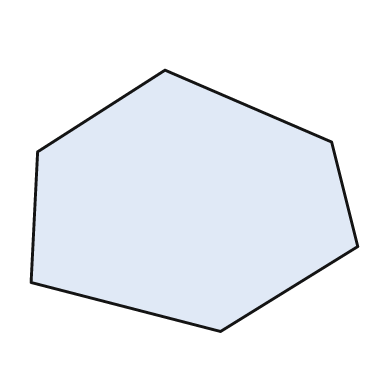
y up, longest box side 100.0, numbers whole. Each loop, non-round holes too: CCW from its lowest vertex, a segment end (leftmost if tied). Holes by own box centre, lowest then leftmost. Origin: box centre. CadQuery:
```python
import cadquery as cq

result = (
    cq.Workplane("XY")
    .moveTo(8.0, -40.0)
    .lineTo(50.0, -14.0)
    .lineTo(42.0, 18.0)
    .lineTo(-9.0, 40.0)
    .lineTo(-48.0, 15.0)
    .lineTo(-50.0, -25.0)
    .close()
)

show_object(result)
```